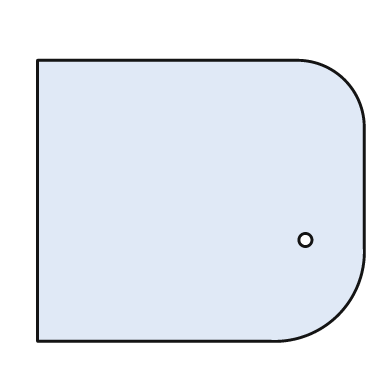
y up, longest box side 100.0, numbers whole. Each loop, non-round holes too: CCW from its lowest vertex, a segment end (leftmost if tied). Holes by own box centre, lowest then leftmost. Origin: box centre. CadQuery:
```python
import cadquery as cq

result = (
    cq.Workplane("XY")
    .moveTo(-50.0, -43.0)
    .lineTo(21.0, -43.0)
    .threePointArc((42.0, -35.0), (50.0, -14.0))
    .lineTo(50.0, 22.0)
    .threePointArc((44.0, 37.0), (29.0, 43.0))
    .lineTo(-50.0, 43.0)
    .close()
    .moveTo(32.0, -12.0)
    .circle(2.0)
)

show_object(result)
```